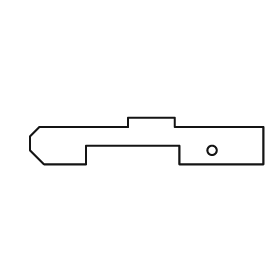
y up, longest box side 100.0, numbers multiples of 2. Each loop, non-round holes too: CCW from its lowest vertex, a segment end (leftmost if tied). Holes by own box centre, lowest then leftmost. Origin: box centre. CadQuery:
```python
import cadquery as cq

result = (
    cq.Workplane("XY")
    .moveTo(-44.0, -10.0)
    .lineTo(-26.0, -10.0)
    .lineTo(-26.0, -2.0)
    .lineTo(14.0, -2.0)
    .lineTo(14.0, -10.0)
    .lineTo(50.0, -10.0)
    .lineTo(50.0, 6.0)
    .lineTo(12.0, 6.0)
    .lineTo(12.0, 10.0)
    .lineTo(-8.0, 10.0)
    .lineTo(-8.0, 6.0)
    .lineTo(-46.0, 6.0)
    .lineTo(-50.0, 2.0)
    .lineTo(-50.0, -4.0)
    .close()
    .moveTo(28.0, -4.0)
    .circle(2.0)
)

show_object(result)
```